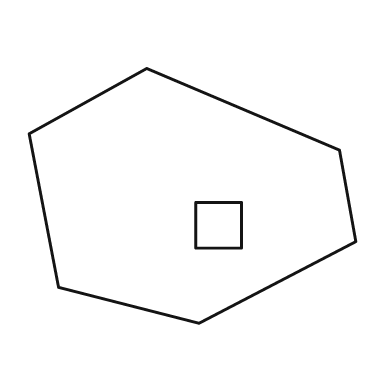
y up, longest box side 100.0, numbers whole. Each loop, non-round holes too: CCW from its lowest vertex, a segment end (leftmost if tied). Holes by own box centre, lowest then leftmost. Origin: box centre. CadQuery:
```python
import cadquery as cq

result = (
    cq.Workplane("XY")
    .moveTo(2.0, -39.0)
    .lineTo(50.0, -14.0)
    .lineTo(45.0, 14.0)
    .lineTo(-14.0, 39.0)
    .lineTo(-50.0, 19.0)
    .lineTo(-41.0, -28.0)
    .close()
    .moveTo(1.0, -16.0)
    .lineTo(15.0, -16.0)
    .lineTo(15.0, -2.0)
    .lineTo(1.0, -2.0)
    .close()
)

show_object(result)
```